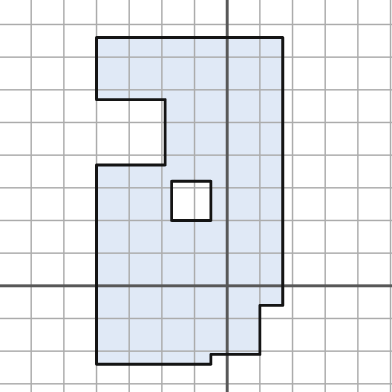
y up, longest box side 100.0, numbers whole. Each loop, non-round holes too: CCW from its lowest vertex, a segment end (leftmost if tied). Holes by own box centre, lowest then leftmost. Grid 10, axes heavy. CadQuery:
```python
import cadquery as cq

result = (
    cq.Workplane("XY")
    .moveTo(-40.0, -24.0)
    .lineTo(-5.0, -24.0)
    .lineTo(-5.0, -21.0)
    .lineTo(10.0, -21.0)
    .lineTo(10.0, -6.0)
    .lineTo(17.0, -6.0)
    .lineTo(17.0, 76.0)
    .lineTo(-40.0, 76.0)
    .lineTo(-40.0, 57.0)
    .lineTo(-19.0, 57.0)
    .lineTo(-19.0, 37.0)
    .lineTo(-40.0, 37.0)
    .close()
    .moveTo(-17.0, 20.0)
    .lineTo(-5.0, 20.0)
    .lineTo(-5.0, 32.0)
    .lineTo(-17.0, 32.0)
    .close()
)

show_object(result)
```